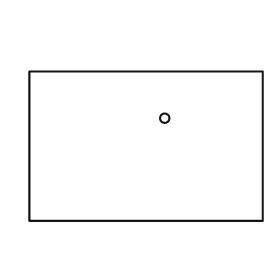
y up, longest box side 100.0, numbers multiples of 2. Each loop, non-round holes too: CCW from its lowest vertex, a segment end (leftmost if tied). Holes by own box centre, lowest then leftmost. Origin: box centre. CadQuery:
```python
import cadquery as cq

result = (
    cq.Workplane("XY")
    .moveTo(-50.0, -32.0)
    .lineTo(50.0, -32.0)
    .lineTo(50.0, 32.0)
    .lineTo(-50.0, 32.0)
    .close()
    .moveTo(8.0, 12.0)
    .circle(2.0)
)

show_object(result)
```